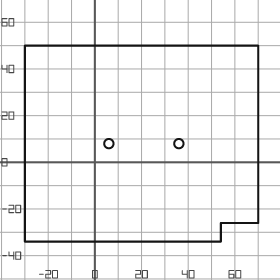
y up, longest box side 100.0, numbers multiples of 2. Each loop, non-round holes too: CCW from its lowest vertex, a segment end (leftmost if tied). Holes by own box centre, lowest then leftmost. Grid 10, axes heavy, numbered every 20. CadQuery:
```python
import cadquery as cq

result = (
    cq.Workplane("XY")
    .moveTo(-30.0, -34.0)
    .lineTo(54.0, -34.0)
    .lineTo(54.0, -26.0)
    .lineTo(70.0, -26.0)
    .lineTo(70.0, 50.0)
    .lineTo(-30.0, 50.0)
    .close()
    .moveTo(6.0, 8.0)
    .circle(2.0)
    .moveTo(36.0, 8.0)
    .circle(2.0)
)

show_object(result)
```